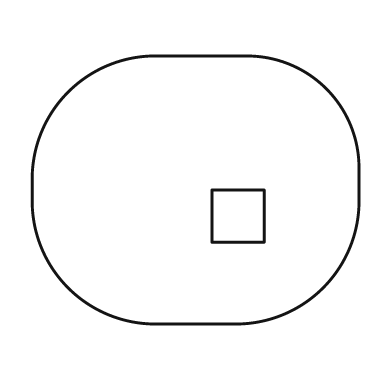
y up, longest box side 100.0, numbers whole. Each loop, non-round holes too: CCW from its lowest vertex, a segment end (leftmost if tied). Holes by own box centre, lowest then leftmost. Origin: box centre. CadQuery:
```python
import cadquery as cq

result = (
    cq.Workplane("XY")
    .moveTo(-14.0, -41.0)
    .lineTo(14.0, -41.0)
    .threePointArc((39.0, -30.0), (50.0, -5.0))
    .lineTo(50.0, 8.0)
    .threePointArc((40.0, 31.0), (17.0, 41.0))
    .lineTo(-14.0, 41.0)
    .threePointArc((-39.0, 30.0), (-50.0, 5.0))
    .lineTo(-50.0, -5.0)
    .threePointArc((-39.0, -30.0), (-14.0, -41.0))
    .close()
    .moveTo(5.0, -16.0)
    .lineTo(21.0, -16.0)
    .lineTo(21.0, 0.0)
    .lineTo(5.0, 0.0)
    .close()
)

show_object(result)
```